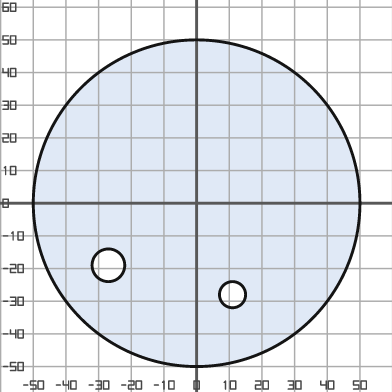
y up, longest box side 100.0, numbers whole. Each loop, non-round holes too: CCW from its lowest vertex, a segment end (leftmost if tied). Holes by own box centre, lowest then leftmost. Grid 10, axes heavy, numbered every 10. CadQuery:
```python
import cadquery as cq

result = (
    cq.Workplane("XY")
    .moveTo(0.0, 0.0)
    .circle(50.0)
    .moveTo(11.0, -28.0)
    .circle(4.0)
    .moveTo(-27.0, -19.0)
    .circle(5.0)
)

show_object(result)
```